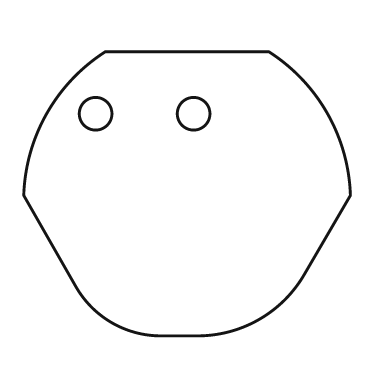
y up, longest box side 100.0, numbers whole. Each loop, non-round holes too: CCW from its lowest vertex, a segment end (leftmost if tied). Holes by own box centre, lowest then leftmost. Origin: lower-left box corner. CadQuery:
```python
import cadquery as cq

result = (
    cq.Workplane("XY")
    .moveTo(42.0, 0.0)
    .lineTo(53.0, 0.0)
    .threePointArc((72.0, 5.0), (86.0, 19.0))
    .lineTo(100.0, 43.0)
    .threePointArc((93.0, 68.0), (75.0, 87.0))
    .lineTo(25.0, 87.0)
    .threePointArc((7.0, 68.0), (0.0, 43.0))
    .lineTo(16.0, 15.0)
    .threePointArc((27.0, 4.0), (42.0, 0.0))
    .close()
    .moveTo(22.0, 68.0)
    .circle(5.0)
    .moveTo(52.0, 68.0)
    .circle(5.0)
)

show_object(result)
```